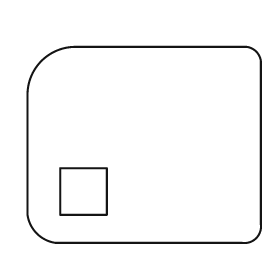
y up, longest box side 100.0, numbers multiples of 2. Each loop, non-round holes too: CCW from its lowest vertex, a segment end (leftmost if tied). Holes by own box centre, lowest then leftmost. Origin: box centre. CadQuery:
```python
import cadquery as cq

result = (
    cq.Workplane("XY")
    .moveTo(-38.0, -42.0)
    .lineTo(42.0, -42.0)
    .threePointArc((48.0, -40.0), (50.0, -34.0))
    .lineTo(50.0, 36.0)
    .threePointArc((48.0, 40.0), (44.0, 42.0))
    .lineTo(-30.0, 42.0)
    .threePointArc((-44.0, 36.0), (-50.0, 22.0))
    .lineTo(-50.0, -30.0)
    .threePointArc((-46.0, -38.0), (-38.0, -42.0))
    .close()
    .moveTo(-36.0, -30.0)
    .lineTo(-16.0, -30.0)
    .lineTo(-16.0, -10.0)
    .lineTo(-36.0, -10.0)
    .close()
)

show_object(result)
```